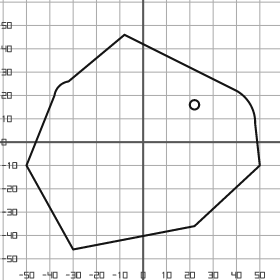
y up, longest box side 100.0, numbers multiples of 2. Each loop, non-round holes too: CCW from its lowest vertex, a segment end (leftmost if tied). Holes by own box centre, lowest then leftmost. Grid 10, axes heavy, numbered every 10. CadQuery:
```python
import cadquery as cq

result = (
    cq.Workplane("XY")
    .moveTo(-30.0, -46.0)
    .lineTo(22.0, -36.0)
    .lineTo(50.0, -10.0)
    .lineTo(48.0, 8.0)
    .threePointArc((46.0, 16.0), (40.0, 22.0))
    .lineTo(-8.0, 46.0)
    .lineTo(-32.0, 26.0)
    .threePointArc((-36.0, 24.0), (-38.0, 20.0))
    .lineTo(-50.0, -10.0)
    .close()
    .moveTo(22.0, 16.0)
    .circle(2.0)
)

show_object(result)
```